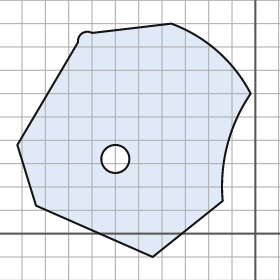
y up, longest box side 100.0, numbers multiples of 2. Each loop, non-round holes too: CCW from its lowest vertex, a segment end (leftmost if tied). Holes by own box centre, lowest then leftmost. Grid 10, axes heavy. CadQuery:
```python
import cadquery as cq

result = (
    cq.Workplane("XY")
    .moveTo(-44.0, -10.0)
    .lineTo(-14.0, 14.0)
    .threePointArc((-12.0, 38.0), (-2.0, 60.0))
    .threePointArc((-16.0, 78.0), (-36.0, 90.0))
    .lineTo(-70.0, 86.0)
    .threePointArc((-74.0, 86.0), (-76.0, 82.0))
    .lineTo(-102.0, 38.0)
    .lineTo(-94.0, 12.0)
    .close()
    .moveTo(-60.0, 32.0)
    .circle(6.0)
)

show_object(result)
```